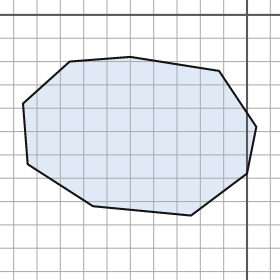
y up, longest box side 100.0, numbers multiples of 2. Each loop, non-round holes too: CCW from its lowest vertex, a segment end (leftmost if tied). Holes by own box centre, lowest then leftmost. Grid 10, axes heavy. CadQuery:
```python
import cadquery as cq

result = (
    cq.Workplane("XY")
    .moveTo(-24.0, -86.0)
    .lineTo(0.0, -68.0)
    .lineTo(4.0, -48.0)
    .lineTo(-12.0, -24.0)
    .lineTo(-50.0, -18.0)
    .lineTo(-76.0, -20.0)
    .lineTo(-96.0, -38.0)
    .lineTo(-94.0, -64.0)
    .lineTo(-66.0, -82.0)
    .close()
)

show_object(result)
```